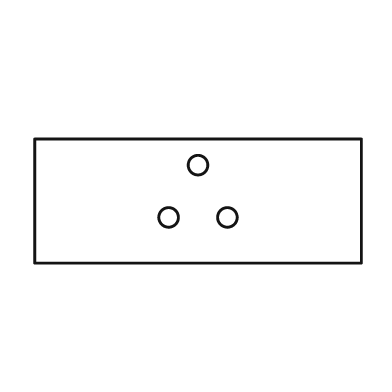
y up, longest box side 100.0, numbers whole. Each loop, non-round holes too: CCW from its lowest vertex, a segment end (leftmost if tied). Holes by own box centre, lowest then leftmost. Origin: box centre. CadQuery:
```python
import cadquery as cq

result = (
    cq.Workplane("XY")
    .moveTo(-50.0, -19.0)
    .lineTo(50.0, -19.0)
    .lineTo(50.0, 19.0)
    .lineTo(-50.0, 19.0)
    .close()
    .moveTo(-9.0, -5.0)
    .circle(3.0)
    .moveTo(9.0, -5.0)
    .circle(3.0)
    .moveTo(0.0, 11.0)
    .circle(3.0)
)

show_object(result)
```